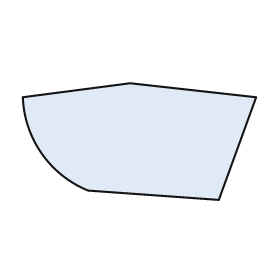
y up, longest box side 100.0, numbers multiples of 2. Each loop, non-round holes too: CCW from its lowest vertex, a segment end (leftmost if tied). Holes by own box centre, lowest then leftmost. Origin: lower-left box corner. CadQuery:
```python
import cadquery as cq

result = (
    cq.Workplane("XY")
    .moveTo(84.0, 0.0)
    .lineTo(100.0, 44.0)
    .lineTo(46.0, 50.0)
    .lineTo(0.0, 44.0)
    .threePointArc((8.0, 20.0), (28.0, 4.0))
    .close()
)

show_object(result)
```